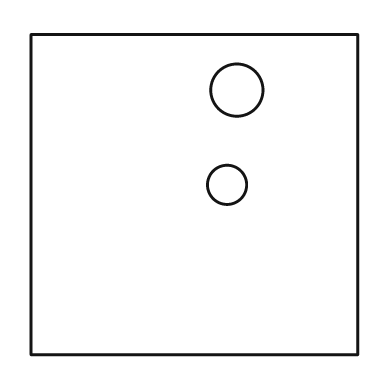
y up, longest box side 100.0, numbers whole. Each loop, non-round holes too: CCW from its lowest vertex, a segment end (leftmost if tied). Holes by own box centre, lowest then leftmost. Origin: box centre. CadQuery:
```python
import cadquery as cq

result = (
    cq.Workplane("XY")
    .moveTo(-50.0, -49.0)
    .lineTo(50.0, -49.0)
    .lineTo(50.0, 49.0)
    .lineTo(-50.0, 49.0)
    .close()
    .moveTo(10.0, 3.0)
    .circle(6.0)
    .moveTo(13.0, 32.0)
    .circle(8.0)
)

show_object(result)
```